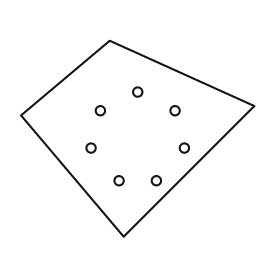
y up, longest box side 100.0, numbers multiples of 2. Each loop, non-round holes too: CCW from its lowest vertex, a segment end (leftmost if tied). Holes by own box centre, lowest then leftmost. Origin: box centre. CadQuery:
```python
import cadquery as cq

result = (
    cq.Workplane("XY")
    .moveTo(-6.0, -42.0)
    .lineTo(50.0, 14.0)
    .lineTo(-12.0, 42.0)
    .lineTo(-50.0, 10.0)
    .close()
    .moveTo(-8.0, -18.0)
    .circle(2.0)
    .moveTo(8.0, -18.0)
    .circle(2.0)
    .moveTo(-20.0, -4.0)
    .circle(2.0)
    .moveTo(20.0, -4.0)
    .circle(2.0)
    .moveTo(-16.0, 12.0)
    .circle(2.0)
    .moveTo(16.0, 12.0)
    .circle(2.0)
    .moveTo(0.0, 20.0)
    .circle(2.0)
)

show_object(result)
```